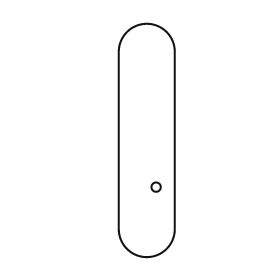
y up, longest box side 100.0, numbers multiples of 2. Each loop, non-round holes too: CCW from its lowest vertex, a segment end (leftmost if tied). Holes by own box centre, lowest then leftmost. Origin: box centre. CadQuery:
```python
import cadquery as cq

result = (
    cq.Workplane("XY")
    .moveTo(-12.0, -38.0)
    .threePointArc((0.0, -50.0), (12.0, -38.0))
    .lineTo(12.0, 38.0)
    .threePointArc((0.0, 50.0), (-12.0, 38.0))
    .close()
    .moveTo(4.0, -20.0)
    .circle(2.0)
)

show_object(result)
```